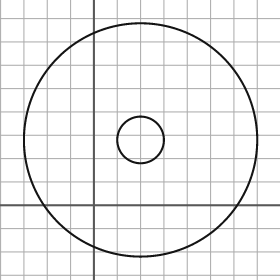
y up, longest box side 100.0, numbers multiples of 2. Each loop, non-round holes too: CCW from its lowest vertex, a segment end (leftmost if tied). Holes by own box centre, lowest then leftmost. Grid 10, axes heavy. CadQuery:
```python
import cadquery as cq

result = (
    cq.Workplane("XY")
    .moveTo(20.0, 28.0)
    .circle(50.0)
    .moveTo(20.0, 28.0)
    .circle(10.0)
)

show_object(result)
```